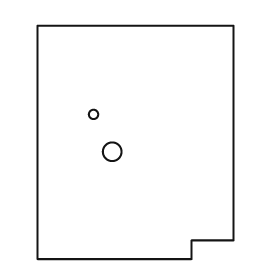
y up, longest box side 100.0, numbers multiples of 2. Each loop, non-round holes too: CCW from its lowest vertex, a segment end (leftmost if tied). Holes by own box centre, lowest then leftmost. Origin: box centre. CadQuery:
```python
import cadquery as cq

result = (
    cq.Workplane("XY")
    .moveTo(-42.0, -50.0)
    .lineTo(24.0, -50.0)
    .lineTo(24.0, -42.0)
    .lineTo(42.0, -42.0)
    .lineTo(42.0, 50.0)
    .lineTo(-42.0, 50.0)
    .close()
    .moveTo(-10.0, -4.0)
    .circle(4.0)
    .moveTo(-18.0, 12.0)
    .circle(2.0)
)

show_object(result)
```